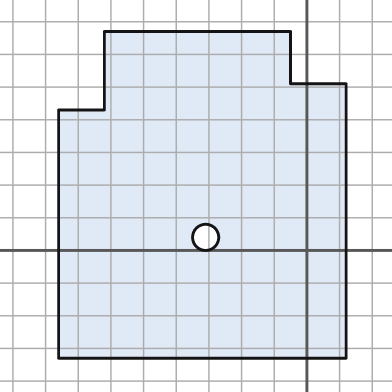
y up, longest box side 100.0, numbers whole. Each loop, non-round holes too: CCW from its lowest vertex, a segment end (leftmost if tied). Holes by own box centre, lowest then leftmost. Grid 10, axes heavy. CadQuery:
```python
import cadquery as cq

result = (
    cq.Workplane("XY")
    .moveTo(-76.0, -33.0)
    .lineTo(12.0, -33.0)
    .lineTo(12.0, 51.0)
    .lineTo(-5.0, 51.0)
    .lineTo(-5.0, 67.0)
    .lineTo(-62.0, 67.0)
    .lineTo(-62.0, 43.0)
    .lineTo(-76.0, 43.0)
    .close()
    .moveTo(-31.0, 4.0)
    .circle(4.0)
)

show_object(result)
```